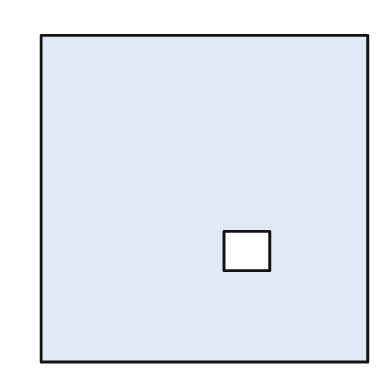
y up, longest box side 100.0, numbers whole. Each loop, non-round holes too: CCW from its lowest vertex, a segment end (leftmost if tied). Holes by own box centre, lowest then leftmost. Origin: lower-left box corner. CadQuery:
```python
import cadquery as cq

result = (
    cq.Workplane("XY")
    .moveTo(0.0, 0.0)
    .lineTo(100.0, 0.0)
    .lineTo(100.0, 100.0)
    .lineTo(0.0, 100.0)
    .close()
    .moveTo(56.0, 28.0)
    .lineTo(70.0, 28.0)
    .lineTo(70.0, 40.0)
    .lineTo(56.0, 40.0)
    .close()
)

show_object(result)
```